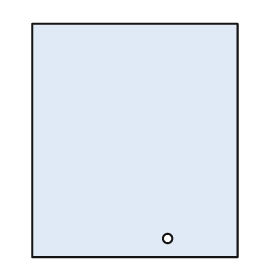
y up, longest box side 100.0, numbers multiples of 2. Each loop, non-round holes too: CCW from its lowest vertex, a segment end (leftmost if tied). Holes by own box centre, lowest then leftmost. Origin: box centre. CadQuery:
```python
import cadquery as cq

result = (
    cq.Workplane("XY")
    .moveTo(-44.0, -50.0)
    .lineTo(44.0, -50.0)
    .lineTo(44.0, 50.0)
    .lineTo(-44.0, 50.0)
    .close()
    .moveTo(14.0, -42.0)
    .circle(2.0)
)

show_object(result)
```